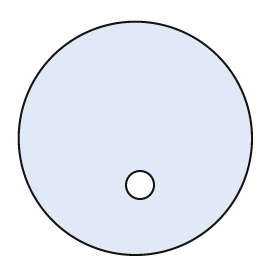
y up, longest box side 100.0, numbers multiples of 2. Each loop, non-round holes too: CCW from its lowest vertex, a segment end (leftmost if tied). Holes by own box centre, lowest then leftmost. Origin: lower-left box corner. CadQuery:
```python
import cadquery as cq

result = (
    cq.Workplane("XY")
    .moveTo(50.0, 50.0)
    .circle(50.0)
    .moveTo(52.0, 30.0)
    .circle(6.0)
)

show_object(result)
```